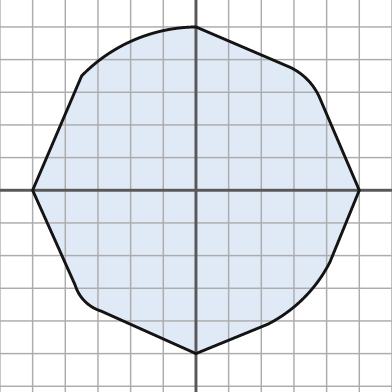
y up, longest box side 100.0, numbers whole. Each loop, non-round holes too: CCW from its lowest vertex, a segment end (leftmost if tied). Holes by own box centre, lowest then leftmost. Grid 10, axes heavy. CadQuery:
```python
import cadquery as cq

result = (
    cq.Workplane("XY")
    .moveTo(0.0, -50.0)
    .lineTo(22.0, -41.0)
    .threePointArc((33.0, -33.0), (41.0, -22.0))
    .lineTo(50.0, 0.0)
    .lineTo(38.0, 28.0)
    .threePointArc((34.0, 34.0), (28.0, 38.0))
    .lineTo(0.0, 50.0)
    .threePointArc((-19.0, 46.0), (-35.0, 35.0))
    .lineTo(-50.0, 0.0)
    .lineTo(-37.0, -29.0)
    .threePointArc((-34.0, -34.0), (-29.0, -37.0))
    .close()
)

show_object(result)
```